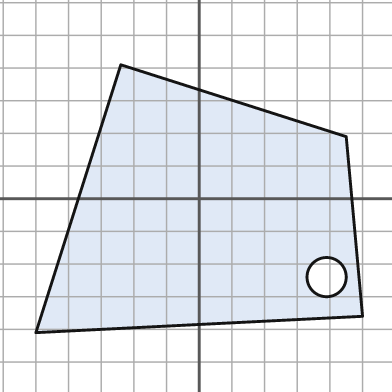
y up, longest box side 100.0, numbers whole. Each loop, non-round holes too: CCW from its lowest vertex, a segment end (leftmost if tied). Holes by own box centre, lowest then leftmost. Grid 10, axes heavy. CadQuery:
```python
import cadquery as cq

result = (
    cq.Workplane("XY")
    .moveTo(-50.0, -41.0)
    .lineTo(50.0, -36.0)
    .lineTo(45.0, 19.0)
    .lineTo(-24.0, 41.0)
    .close()
    .moveTo(39.0, -24.0)
    .circle(6.0)
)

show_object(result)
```